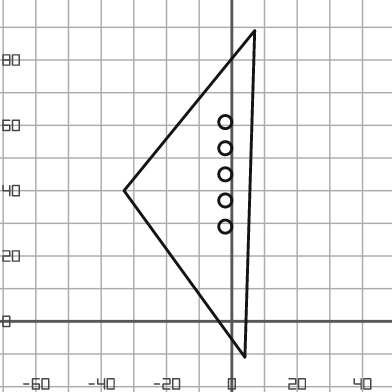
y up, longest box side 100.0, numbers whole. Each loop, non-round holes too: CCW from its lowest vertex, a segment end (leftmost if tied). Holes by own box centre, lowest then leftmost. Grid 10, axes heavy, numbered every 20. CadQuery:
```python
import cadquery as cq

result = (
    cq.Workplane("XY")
    .moveTo(4.0, -11.0)
    .lineTo(7.0, 89.0)
    .lineTo(-33.0, 40.0)
    .close()
    .moveTo(-2.0, 29.0)
    .circle(2.0)
    .moveTo(-2.0, 37.0)
    .circle(2.0)
    .moveTo(-2.0, 45.0)
    .circle(2.0)
    .moveTo(-2.0, 53.0)
    .circle(2.0)
    .moveTo(-2.0, 61.0)
    .circle(2.0)
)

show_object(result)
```